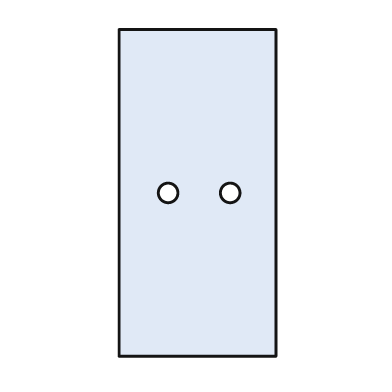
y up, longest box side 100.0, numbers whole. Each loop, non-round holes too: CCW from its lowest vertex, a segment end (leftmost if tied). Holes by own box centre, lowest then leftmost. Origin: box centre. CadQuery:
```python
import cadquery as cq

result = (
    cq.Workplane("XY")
    .moveTo(-24.0, -50.0)
    .lineTo(24.0, -50.0)
    .lineTo(24.0, 50.0)
    .lineTo(-24.0, 50.0)
    .close()
    .moveTo(-9.0, 0.0)
    .circle(3.0)
    .moveTo(10.0, 0.0)
    .circle(3.0)
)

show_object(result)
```